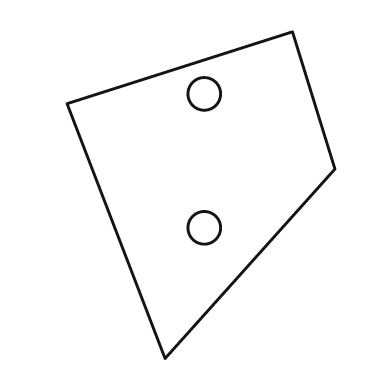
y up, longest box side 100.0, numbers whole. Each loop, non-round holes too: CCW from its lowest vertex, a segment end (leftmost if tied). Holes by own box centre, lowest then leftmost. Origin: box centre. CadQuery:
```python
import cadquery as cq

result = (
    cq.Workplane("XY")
    .moveTo(-11.0, -50.0)
    .lineTo(41.0, 8.0)
    .lineTo(28.0, 50.0)
    .lineTo(-41.0, 28.0)
    .close()
    .moveTo(1.0, -10.0)
    .circle(5.0)
    .moveTo(1.0, 31.0)
    .circle(5.0)
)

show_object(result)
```